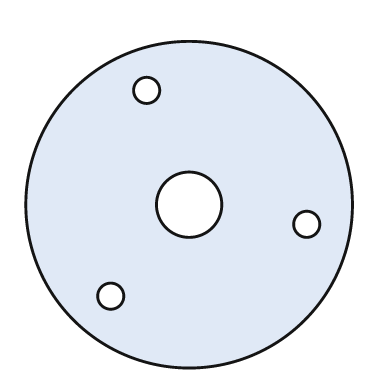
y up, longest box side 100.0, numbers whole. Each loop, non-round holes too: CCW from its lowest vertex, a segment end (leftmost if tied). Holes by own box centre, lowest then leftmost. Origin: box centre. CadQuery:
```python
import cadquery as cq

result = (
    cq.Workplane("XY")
    .moveTo(0.0, 0.0)
    .circle(50.0)
    .moveTo(-24.0, -28.0)
    .circle(4.0)
    .moveTo(36.0, -6.0)
    .circle(4.0)
    .moveTo(0.0, 0.0)
    .circle(10.0)
    .moveTo(-13.0, 35.0)
    .circle(4.0)
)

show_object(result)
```